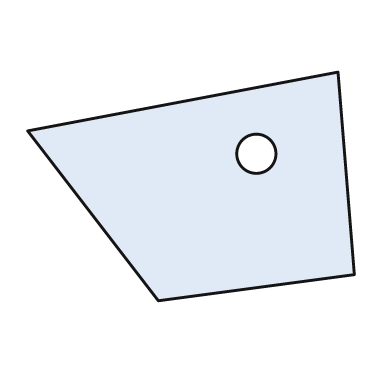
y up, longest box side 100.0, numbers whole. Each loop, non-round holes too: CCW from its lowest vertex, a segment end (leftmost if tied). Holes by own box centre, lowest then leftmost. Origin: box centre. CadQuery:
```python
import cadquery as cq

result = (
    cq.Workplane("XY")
    .moveTo(-10.0, -35.0)
    .lineTo(50.0, -27.0)
    .lineTo(45.0, 35.0)
    .lineTo(-50.0, 17.0)
    .close()
    .moveTo(20.0, 10.0)
    .circle(6.0)
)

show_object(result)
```